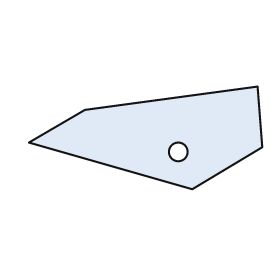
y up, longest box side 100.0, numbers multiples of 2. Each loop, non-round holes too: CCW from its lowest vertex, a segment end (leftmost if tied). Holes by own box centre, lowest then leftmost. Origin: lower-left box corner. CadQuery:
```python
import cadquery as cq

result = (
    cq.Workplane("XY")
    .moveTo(70.0, 0.0)
    .lineTo(100.0, 18.0)
    .lineTo(98.0, 44.0)
    .lineTo(24.0, 34.0)
    .lineTo(0.0, 20.0)
    .close()
    .moveTo(64.0, 16.0)
    .circle(4.0)
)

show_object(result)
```